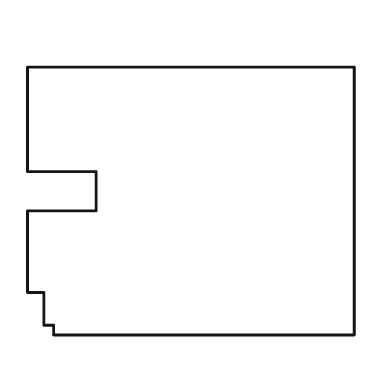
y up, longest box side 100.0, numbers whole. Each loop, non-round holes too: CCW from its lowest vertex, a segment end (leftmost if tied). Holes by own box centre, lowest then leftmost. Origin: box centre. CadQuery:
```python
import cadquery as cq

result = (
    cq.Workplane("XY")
    .moveTo(-42.0, -41.0)
    .lineTo(50.0, -41.0)
    .lineTo(50.0, 41.0)
    .lineTo(-50.0, 41.0)
    .lineTo(-50.0, 9.0)
    .lineTo(-29.0, 9.0)
    .lineTo(-29.0, -3.0)
    .lineTo(-50.0, -3.0)
    .lineTo(-50.0, -28.0)
    .lineTo(-45.0, -28.0)
    .lineTo(-45.0, -38.0)
    .lineTo(-42.0, -38.0)
    .close()
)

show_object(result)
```